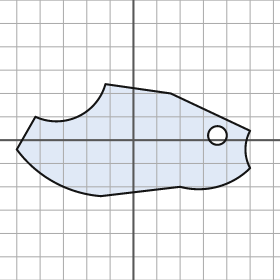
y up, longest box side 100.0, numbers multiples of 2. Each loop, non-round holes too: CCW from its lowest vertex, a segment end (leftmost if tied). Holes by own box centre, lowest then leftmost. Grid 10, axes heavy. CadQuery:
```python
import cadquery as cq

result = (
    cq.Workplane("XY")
    .moveTo(-14.0, -24.0)
    .lineTo(20.0, -20.0)
    .threePointArc((36.0, -20.0), (50.0, -12.0))
    .threePointArc((48.0, -4.0), (50.0, 4.0))
    .lineTo(16.0, 20.0)
    .lineTo(-12.0, 24.0)
    .threePointArc((-24.0, 10.0), (-42.0, 10.0))
    .lineTo(-50.0, -4.0)
    .threePointArc((-34.0, -18.0), (-14.0, -24.0))
    .close()
    .moveTo(36.0, 2.0)
    .circle(4.0)
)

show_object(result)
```